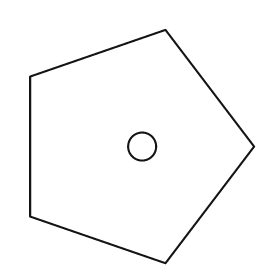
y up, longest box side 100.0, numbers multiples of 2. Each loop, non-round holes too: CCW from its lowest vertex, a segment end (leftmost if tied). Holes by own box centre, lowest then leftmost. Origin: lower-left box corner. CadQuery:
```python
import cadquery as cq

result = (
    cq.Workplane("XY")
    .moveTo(58.0, 0.0)
    .lineTo(96.0, 50.0)
    .lineTo(58.0, 100.0)
    .lineTo(0.0, 80.0)
    .lineTo(0.0, 20.0)
    .close()
    .moveTo(48.0, 50.0)
    .circle(6.0)
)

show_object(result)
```